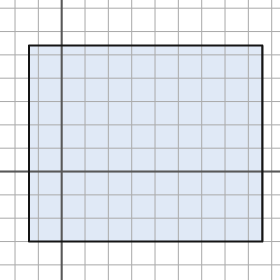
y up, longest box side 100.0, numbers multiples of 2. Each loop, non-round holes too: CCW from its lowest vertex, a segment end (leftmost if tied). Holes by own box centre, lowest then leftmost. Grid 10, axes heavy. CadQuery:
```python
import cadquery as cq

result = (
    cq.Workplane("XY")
    .moveTo(-14.0, -30.0)
    .lineTo(86.0, -30.0)
    .lineTo(86.0, 54.0)
    .lineTo(-14.0, 54.0)
    .close()
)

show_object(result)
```